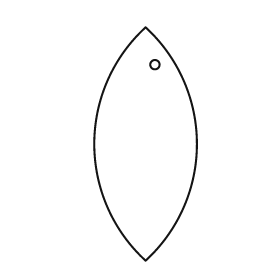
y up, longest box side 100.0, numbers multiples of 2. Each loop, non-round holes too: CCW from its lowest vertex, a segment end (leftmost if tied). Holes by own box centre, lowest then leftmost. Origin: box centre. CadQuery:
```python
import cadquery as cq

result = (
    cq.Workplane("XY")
    .moveTo(0.0, -50.0)
    .threePointArc((22.0, 0.0), (0.0, 50.0))
    .threePointArc((-22.0, 0.0), (0.0, -50.0))
    .close()
    .moveTo(4.0, 34.0)
    .circle(2.0)
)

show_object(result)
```